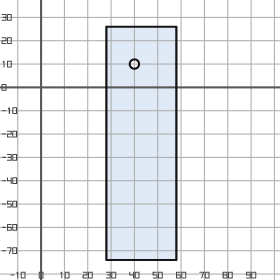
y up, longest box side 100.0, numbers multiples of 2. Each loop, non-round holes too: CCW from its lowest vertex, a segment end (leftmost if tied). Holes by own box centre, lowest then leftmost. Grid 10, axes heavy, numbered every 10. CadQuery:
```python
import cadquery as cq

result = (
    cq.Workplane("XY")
    .moveTo(28.0, -74.0)
    .lineTo(58.0, -74.0)
    .lineTo(58.0, 26.0)
    .lineTo(28.0, 26.0)
    .close()
    .moveTo(40.0, 10.0)
    .circle(2.0)
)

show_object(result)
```